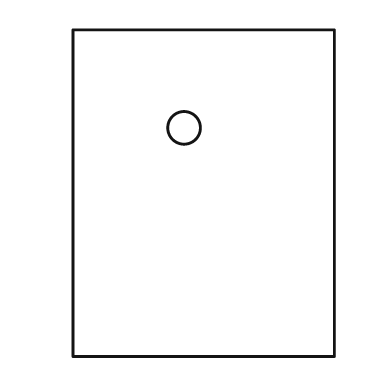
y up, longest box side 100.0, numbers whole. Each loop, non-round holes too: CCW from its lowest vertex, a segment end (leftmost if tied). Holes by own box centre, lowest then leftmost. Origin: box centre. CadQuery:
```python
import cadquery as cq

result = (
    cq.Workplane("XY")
    .moveTo(-40.0, -50.0)
    .lineTo(40.0, -50.0)
    .lineTo(40.0, 50.0)
    .lineTo(-40.0, 50.0)
    .close()
    .moveTo(-6.0, 20.0)
    .circle(5.0)
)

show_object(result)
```